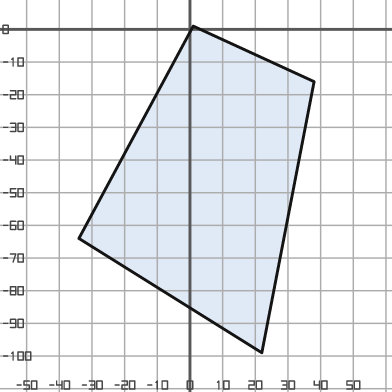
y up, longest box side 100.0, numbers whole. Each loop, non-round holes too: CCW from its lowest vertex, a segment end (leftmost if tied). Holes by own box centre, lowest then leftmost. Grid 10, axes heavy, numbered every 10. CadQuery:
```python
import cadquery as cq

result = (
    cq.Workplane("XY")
    .moveTo(22.0, -99.0)
    .lineTo(38.0, -16.0)
    .lineTo(1.0, 1.0)
    .lineTo(-34.0, -64.0)
    .close()
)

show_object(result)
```